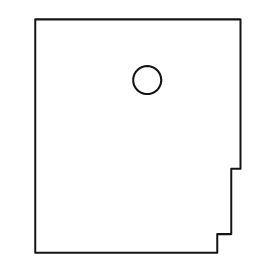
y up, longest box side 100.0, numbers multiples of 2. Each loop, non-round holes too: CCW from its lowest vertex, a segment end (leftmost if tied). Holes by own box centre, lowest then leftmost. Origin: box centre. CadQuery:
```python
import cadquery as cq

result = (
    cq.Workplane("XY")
    .moveTo(-44.0, -50.0)
    .lineTo(34.0, -50.0)
    .lineTo(34.0, -42.0)
    .lineTo(40.0, -42.0)
    .lineTo(40.0, -14.0)
    .lineTo(44.0, -14.0)
    .lineTo(44.0, 50.0)
    .lineTo(-44.0, 50.0)
    .close()
    .moveTo(4.0, 24.0)
    .circle(6.0)
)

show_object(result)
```